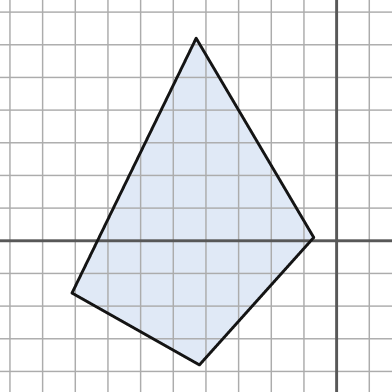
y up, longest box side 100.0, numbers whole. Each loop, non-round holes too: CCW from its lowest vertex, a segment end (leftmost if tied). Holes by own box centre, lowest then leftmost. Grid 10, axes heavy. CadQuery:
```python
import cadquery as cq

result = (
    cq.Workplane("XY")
    .moveTo(-42.0, -38.0)
    .lineTo(-7.0, 1.0)
    .lineTo(-43.0, 62.0)
    .lineTo(-81.0, -16.0)
    .close()
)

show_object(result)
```